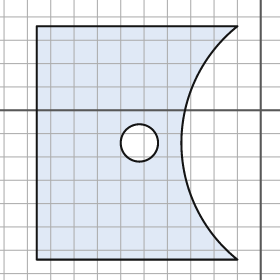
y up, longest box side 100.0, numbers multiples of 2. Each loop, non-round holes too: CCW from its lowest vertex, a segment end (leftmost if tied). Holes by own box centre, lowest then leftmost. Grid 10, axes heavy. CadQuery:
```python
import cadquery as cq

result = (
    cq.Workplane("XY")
    .moveTo(-96.0, -64.0)
    .lineTo(-10.0, -64.0)
    .threePointArc((-34.0, -14.0), (-10.0, 36.0))
    .lineTo(-96.0, 36.0)
    .close()
    .moveTo(-52.0, -14.0)
    .circle(8.0)
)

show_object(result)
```